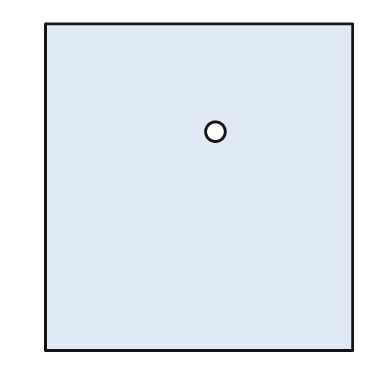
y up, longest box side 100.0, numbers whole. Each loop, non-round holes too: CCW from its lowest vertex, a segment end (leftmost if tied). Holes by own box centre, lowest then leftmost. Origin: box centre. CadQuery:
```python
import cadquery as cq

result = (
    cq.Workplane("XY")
    .moveTo(-47.0, -50.0)
    .lineTo(47.0, -50.0)
    .lineTo(47.0, 50.0)
    .lineTo(-47.0, 50.0)
    .close()
    .moveTo(5.0, 17.0)
    .circle(3.0)
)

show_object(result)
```